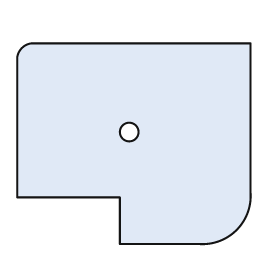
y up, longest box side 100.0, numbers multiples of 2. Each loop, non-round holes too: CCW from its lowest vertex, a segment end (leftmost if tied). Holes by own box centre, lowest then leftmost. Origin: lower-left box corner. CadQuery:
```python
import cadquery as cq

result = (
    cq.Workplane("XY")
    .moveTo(44.0, 0.0)
    .lineTo(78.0, 0.0)
    .threePointArc((94.0, 6.0), (100.0, 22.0))
    .lineTo(100.0, 86.0)
    .lineTo(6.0, 86.0)
    .threePointArc((2.0, 84.0), (0.0, 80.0))
    .lineTo(0.0, 20.0)
    .lineTo(44.0, 20.0)
    .close()
    .moveTo(48.0, 48.0)
    .circle(4.0)
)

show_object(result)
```